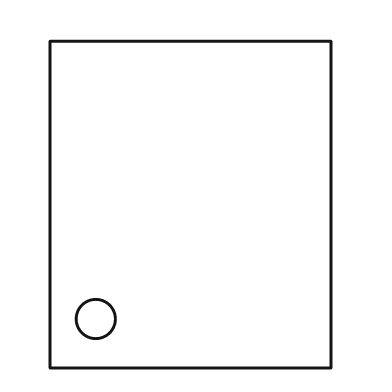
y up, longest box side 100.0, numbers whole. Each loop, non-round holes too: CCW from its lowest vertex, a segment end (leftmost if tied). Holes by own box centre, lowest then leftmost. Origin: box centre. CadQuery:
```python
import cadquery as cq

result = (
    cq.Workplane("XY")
    .moveTo(-43.0, -50.0)
    .lineTo(43.0, -50.0)
    .lineTo(43.0, 50.0)
    .lineTo(-43.0, 50.0)
    .close()
    .moveTo(-29.0, -35.0)
    .circle(6.0)
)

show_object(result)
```